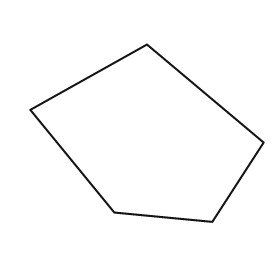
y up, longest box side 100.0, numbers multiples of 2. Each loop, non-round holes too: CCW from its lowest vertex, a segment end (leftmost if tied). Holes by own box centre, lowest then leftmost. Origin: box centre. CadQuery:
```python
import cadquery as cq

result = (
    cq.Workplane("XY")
    .moveTo(28.0, -38.0)
    .lineTo(50.0, -4.0)
    .lineTo(0.0, 38.0)
    .lineTo(-50.0, 10.0)
    .lineTo(-14.0, -34.0)
    .close()
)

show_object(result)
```